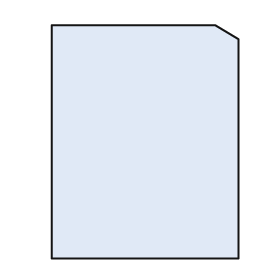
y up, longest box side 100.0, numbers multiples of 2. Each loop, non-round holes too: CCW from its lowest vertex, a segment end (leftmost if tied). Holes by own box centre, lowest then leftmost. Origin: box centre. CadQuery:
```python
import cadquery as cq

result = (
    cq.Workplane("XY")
    .moveTo(-40.0, -50.0)
    .lineTo(40.0, -50.0)
    .lineTo(40.0, 44.0)
    .lineTo(30.0, 50.0)
    .lineTo(-40.0, 50.0)
    .close()
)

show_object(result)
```